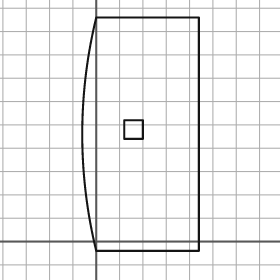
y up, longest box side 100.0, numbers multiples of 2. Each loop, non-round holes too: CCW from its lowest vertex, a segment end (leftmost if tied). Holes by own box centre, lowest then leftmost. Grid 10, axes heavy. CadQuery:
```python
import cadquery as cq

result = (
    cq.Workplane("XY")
    .moveTo(0.0, -4.0)
    .lineTo(44.0, -4.0)
    .lineTo(44.0, 96.0)
    .lineTo(0.0, 96.0)
    .threePointArc((-6.0, 46.0), (0.0, -4.0))
    .close()
    .moveTo(12.0, 44.0)
    .lineTo(20.0, 44.0)
    .lineTo(20.0, 52.0)
    .lineTo(12.0, 52.0)
    .close()
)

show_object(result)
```